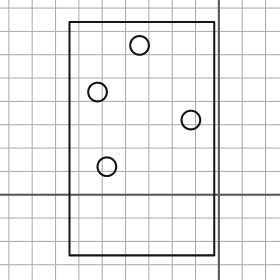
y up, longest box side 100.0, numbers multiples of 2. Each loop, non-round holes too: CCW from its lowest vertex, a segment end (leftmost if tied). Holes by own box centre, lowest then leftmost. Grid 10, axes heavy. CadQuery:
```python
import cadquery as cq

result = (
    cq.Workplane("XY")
    .moveTo(-64.0, -26.0)
    .lineTo(-2.0, -26.0)
    .lineTo(-2.0, 74.0)
    .lineTo(-64.0, 74.0)
    .close()
    .moveTo(-48.0, 12.0)
    .circle(4.0)
    .moveTo(-12.0, 32.0)
    .circle(4.0)
    .moveTo(-52.0, 44.0)
    .circle(4.0)
    .moveTo(-34.0, 64.0)
    .circle(4.0)
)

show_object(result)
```